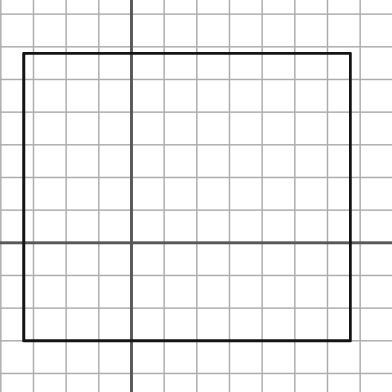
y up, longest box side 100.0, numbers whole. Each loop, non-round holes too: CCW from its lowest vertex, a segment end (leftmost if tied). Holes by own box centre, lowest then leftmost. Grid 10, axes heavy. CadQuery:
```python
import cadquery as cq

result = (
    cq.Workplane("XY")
    .moveTo(-33.0, -30.0)
    .lineTo(67.0, -30.0)
    .lineTo(67.0, 58.0)
    .lineTo(-33.0, 58.0)
    .close()
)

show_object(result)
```